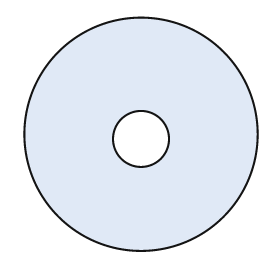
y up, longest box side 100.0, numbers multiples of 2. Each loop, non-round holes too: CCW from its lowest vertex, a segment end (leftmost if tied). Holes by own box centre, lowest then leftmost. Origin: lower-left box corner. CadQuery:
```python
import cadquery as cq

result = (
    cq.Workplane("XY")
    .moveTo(50.0, 50.0)
    .circle(50.0)
    .moveTo(50.0, 48.0)
    .circle(12.0)
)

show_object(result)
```